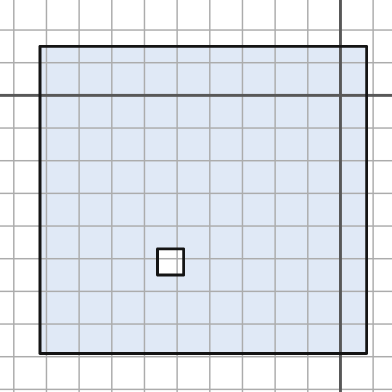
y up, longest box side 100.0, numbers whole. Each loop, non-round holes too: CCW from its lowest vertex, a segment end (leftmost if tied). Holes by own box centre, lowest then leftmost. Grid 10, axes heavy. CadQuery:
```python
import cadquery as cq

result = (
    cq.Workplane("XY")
    .moveTo(-92.0, -79.0)
    .lineTo(8.0, -79.0)
    .lineTo(8.0, 15.0)
    .lineTo(-92.0, 15.0)
    .close()
    .moveTo(-56.0, -55.0)
    .lineTo(-48.0, -55.0)
    .lineTo(-48.0, -47.0)
    .lineTo(-56.0, -47.0)
    .close()
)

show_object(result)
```